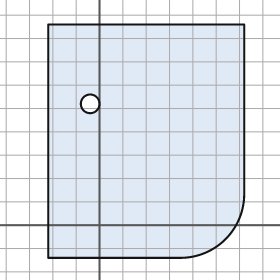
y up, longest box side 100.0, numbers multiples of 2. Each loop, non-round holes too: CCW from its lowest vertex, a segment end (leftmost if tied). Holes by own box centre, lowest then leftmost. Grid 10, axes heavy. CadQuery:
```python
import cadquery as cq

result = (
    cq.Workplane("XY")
    .moveTo(-22.0, -14.0)
    .lineTo(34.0, -14.0)
    .threePointArc((54.0, -6.0), (62.0, 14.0))
    .lineTo(62.0, 86.0)
    .lineTo(-22.0, 86.0)
    .close()
    .moveTo(-4.0, 52.0)
    .circle(4.0)
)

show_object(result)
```